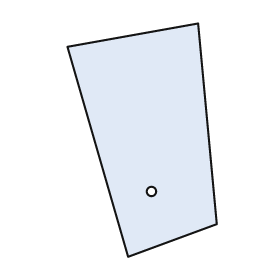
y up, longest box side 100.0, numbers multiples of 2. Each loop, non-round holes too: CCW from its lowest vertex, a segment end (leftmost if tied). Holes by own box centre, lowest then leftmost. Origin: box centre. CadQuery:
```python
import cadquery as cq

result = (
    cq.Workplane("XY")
    .moveTo(-6.0, -50.0)
    .lineTo(32.0, -36.0)
    .lineTo(24.0, 50.0)
    .lineTo(-32.0, 40.0)
    .close()
    .moveTo(4.0, -22.0)
    .circle(2.0)
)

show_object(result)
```